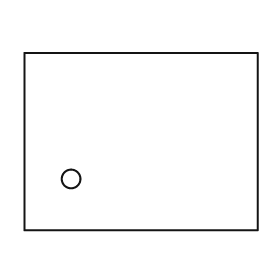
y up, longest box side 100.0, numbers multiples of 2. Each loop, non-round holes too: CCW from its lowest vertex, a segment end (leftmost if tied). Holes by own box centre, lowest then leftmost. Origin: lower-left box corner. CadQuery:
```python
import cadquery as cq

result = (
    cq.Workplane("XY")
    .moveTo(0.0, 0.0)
    .lineTo(100.0, 0.0)
    .lineTo(100.0, 76.0)
    .lineTo(0.0, 76.0)
    .close()
    .moveTo(20.0, 22.0)
    .circle(4.0)
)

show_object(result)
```